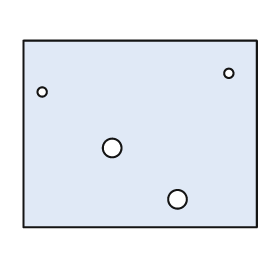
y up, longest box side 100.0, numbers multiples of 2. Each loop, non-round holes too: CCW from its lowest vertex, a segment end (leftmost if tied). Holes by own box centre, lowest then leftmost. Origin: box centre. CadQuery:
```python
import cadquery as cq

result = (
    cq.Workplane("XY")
    .moveTo(-50.0, -40.0)
    .lineTo(50.0, -40.0)
    .lineTo(50.0, 40.0)
    .lineTo(-50.0, 40.0)
    .close()
    .moveTo(16.0, -28.0)
    .circle(4.0)
    .moveTo(-12.0, -6.0)
    .circle(4.0)
    .moveTo(-42.0, 18.0)
    .circle(2.0)
    .moveTo(38.0, 26.0)
    .circle(2.0)
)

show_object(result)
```